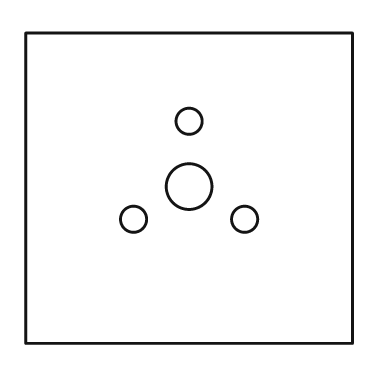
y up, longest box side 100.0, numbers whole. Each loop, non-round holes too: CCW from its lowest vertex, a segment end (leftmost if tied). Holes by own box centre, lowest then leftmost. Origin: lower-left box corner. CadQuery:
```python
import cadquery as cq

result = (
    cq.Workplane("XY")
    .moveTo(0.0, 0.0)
    .lineTo(100.0, 0.0)
    .lineTo(100.0, 95.0)
    .lineTo(0.0, 95.0)
    .close()
    .moveTo(33.0, 38.0)
    .circle(4.0)
    .moveTo(67.0, 38.0)
    .circle(4.0)
    .moveTo(50.0, 48.0)
    .circle(7.0)
    .moveTo(50.0, 68.0)
    .circle(4.0)
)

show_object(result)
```